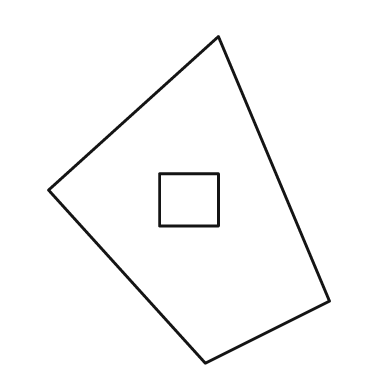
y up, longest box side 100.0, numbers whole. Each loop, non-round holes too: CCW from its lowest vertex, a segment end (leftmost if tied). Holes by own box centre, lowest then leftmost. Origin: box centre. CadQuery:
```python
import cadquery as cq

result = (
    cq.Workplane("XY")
    .moveTo(5.0, -50.0)
    .lineTo(43.0, -31.0)
    .lineTo(9.0, 50.0)
    .lineTo(-43.0, 3.0)
    .close()
    .moveTo(-9.0, -8.0)
    .lineTo(9.0, -8.0)
    .lineTo(9.0, 8.0)
    .lineTo(-9.0, 8.0)
    .close()
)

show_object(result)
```